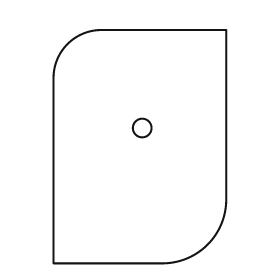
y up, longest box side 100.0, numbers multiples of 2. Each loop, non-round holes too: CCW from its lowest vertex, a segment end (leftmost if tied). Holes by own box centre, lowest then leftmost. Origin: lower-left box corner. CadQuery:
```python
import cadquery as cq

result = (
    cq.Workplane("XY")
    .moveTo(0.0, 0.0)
    .lineTo(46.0, 0.0)
    .threePointArc((66.0, 8.0), (74.0, 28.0))
    .lineTo(74.0, 100.0)
    .lineTo(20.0, 100.0)
    .threePointArc((6.0, 94.0), (0.0, 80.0))
    .close()
    .moveTo(38.0, 58.0)
    .circle(4.0)
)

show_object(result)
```